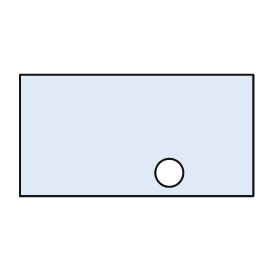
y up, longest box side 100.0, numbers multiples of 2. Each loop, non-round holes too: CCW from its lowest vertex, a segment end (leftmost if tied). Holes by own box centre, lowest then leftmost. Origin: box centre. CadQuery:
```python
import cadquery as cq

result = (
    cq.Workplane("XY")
    .moveTo(-50.0, -26.0)
    .lineTo(50.0, -26.0)
    .lineTo(50.0, 26.0)
    .lineTo(-50.0, 26.0)
    .close()
    .moveTo(14.0, -16.0)
    .circle(6.0)
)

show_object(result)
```